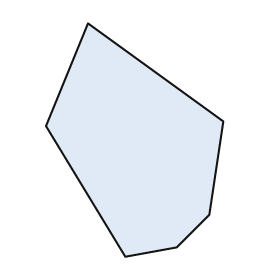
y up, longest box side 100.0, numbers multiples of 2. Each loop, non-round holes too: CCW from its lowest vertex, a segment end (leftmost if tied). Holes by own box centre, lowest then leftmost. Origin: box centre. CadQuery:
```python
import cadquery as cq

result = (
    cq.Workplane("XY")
    .moveTo(-4.0, -50.0)
    .lineTo(18.0, -46.0)
    .lineTo(32.0, -32.0)
    .lineTo(38.0, 8.0)
    .lineTo(-20.0, 50.0)
    .lineTo(-38.0, 6.0)
    .close()
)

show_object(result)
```